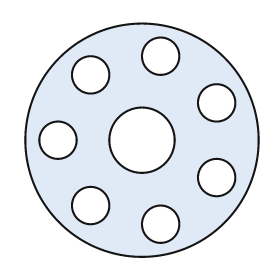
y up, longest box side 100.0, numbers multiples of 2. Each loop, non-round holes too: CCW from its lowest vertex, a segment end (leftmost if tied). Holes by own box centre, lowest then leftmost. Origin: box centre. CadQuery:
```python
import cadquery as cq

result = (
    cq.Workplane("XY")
    .moveTo(0.0, 0.0)
    .circle(50.0)
    .moveTo(8.0, -36.0)
    .circle(8.0)
    .moveTo(-22.0, -28.0)
    .circle(8.0)
    .moveTo(32.0, -16.0)
    .circle(8.0)
    .moveTo(-36.0, 0.0)
    .circle(8.0)
    .moveTo(0.0, 0.0)
    .circle(14.0)
    .moveTo(32.0, 16.0)
    .circle(8.0)
    .moveTo(-22.0, 28.0)
    .circle(8.0)
    .moveTo(8.0, 36.0)
    .circle(8.0)
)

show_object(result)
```